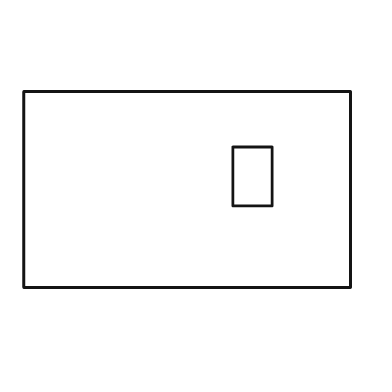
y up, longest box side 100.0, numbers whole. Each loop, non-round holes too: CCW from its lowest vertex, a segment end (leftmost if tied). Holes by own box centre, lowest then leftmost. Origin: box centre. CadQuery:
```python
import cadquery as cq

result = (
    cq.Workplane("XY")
    .moveTo(-50.0, -30.0)
    .lineTo(50.0, -30.0)
    .lineTo(50.0, 30.0)
    .lineTo(-50.0, 30.0)
    .close()
    .moveTo(14.0, -5.0)
    .lineTo(26.0, -5.0)
    .lineTo(26.0, 13.0)
    .lineTo(14.0, 13.0)
    .close()
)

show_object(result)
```